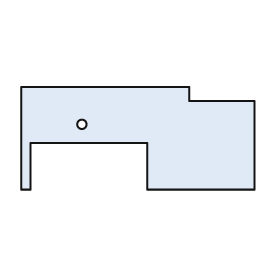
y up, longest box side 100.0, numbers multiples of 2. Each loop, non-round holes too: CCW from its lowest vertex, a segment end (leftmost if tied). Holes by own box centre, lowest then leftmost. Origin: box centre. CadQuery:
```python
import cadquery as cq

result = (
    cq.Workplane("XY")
    .moveTo(-50.0, -22.0)
    .lineTo(-46.0, -22.0)
    .lineTo(-46.0, -2.0)
    .lineTo(4.0, -2.0)
    .lineTo(4.0, -22.0)
    .lineTo(50.0, -22.0)
    .lineTo(50.0, 16.0)
    .lineTo(22.0, 16.0)
    .lineTo(22.0, 22.0)
    .lineTo(-50.0, 22.0)
    .close()
    .moveTo(-24.0, 6.0)
    .circle(2.0)
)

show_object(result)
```